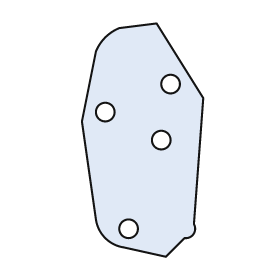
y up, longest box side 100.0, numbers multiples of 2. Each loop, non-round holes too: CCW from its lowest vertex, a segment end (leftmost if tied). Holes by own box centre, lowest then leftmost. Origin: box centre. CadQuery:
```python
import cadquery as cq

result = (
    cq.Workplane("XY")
    .moveTo(10.0, -50.0)
    .lineTo(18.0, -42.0)
    .threePointArc((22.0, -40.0), (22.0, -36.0))
    .lineTo(26.0, 18.0)
    .lineTo(6.0, 50.0)
    .lineTo(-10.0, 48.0)
    .threePointArc((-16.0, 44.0), (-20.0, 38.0))
    .lineTo(-26.0, 8.0)
    .lineTo(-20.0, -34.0)
    .threePointArc((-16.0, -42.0), (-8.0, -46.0))
    .close()
    .moveTo(-6.0, -38.0)
    .circle(4.0)
    .moveTo(8.0, 0.0)
    .circle(4.0)
    .moveTo(-16.0, 12.0)
    .circle(4.0)
    .moveTo(12.0, 24.0)
    .circle(4.0)
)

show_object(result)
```